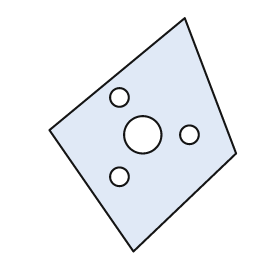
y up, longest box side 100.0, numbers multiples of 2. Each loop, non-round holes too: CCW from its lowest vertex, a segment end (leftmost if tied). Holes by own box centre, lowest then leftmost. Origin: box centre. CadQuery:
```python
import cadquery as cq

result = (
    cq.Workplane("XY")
    .moveTo(-4.0, -50.0)
    .lineTo(40.0, -8.0)
    .lineTo(18.0, 50.0)
    .lineTo(-40.0, 2.0)
    .close()
    .moveTo(-10.0, -18.0)
    .circle(4.0)
    .moveTo(0.0, 0.0)
    .circle(8.0)
    .moveTo(20.0, 0.0)
    .circle(4.0)
    .moveTo(-10.0, 16.0)
    .circle(4.0)
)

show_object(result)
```